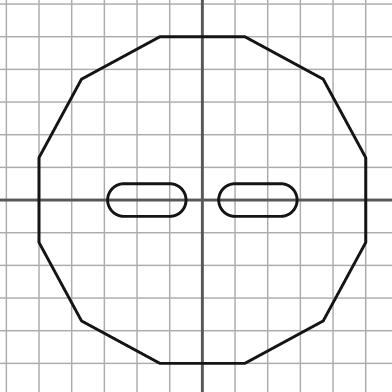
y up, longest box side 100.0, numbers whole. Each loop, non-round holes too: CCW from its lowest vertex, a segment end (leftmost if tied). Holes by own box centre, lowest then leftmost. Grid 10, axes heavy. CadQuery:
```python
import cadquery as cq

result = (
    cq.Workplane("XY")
    .moveTo(-13.0, -50.0)
    .lineTo(13.0, -50.0)
    .lineTo(37.0, -37.0)
    .lineTo(50.0, -13.0)
    .lineTo(50.0, 13.0)
    .lineTo(37.0, 37.0)
    .lineTo(13.0, 50.0)
    .lineTo(-13.0, 50.0)
    .lineTo(-37.0, 37.0)
    .lineTo(-50.0, 13.0)
    .lineTo(-50.0, -13.0)
    .lineTo(-37.0, -37.0)
    .close()
    .moveTo(-24.0, -5.0)
    .lineTo(-10.0, -5.0)
    .threePointArc((-5.0, 0.0), (-10.0, 5.0))
    .lineTo(-24.0, 5.0)
    .threePointArc((-29.0, 0.0), (-24.0, -5.0))
    .close()
    .moveTo(10.0, -5.0)
    .lineTo(24.0, -5.0)
    .threePointArc((29.0, 0.0), (24.0, 5.0))
    .lineTo(10.0, 5.0)
    .threePointArc((5.0, 0.0), (10.0, -5.0))
    .close()
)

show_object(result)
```